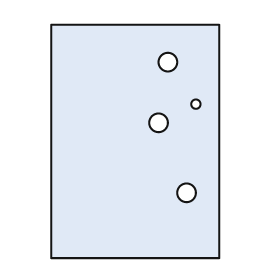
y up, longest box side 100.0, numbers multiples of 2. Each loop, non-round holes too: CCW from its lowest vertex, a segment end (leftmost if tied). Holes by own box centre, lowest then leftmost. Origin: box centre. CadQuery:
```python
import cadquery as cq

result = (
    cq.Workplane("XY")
    .moveTo(-36.0, -50.0)
    .lineTo(36.0, -50.0)
    .lineTo(36.0, 50.0)
    .lineTo(-36.0, 50.0)
    .close()
    .moveTo(22.0, -22.0)
    .circle(4.0)
    .moveTo(10.0, 8.0)
    .circle(4.0)
    .moveTo(26.0, 16.0)
    .circle(2.0)
    .moveTo(14.0, 34.0)
    .circle(4.0)
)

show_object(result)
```